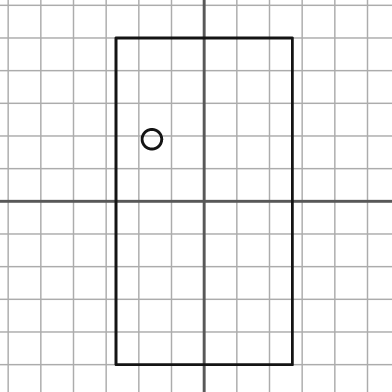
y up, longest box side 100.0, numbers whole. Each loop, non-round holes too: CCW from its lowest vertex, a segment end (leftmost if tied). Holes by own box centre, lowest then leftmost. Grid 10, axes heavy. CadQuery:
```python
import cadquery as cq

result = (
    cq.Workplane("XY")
    .moveTo(-27.0, -50.0)
    .lineTo(27.0, -50.0)
    .lineTo(27.0, 50.0)
    .lineTo(-27.0, 50.0)
    .close()
    .moveTo(-16.0, 19.0)
    .circle(3.0)
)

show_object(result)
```